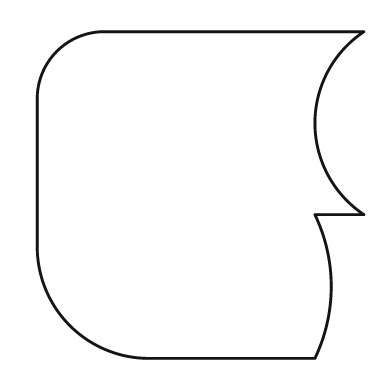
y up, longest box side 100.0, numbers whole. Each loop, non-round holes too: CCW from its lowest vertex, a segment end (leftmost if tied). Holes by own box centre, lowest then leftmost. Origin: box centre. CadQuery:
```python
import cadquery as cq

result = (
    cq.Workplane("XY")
    .moveTo(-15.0, -50.0)
    .lineTo(35.0, -50.0)
    .threePointArc((40.0, -28.0), (35.0, -6.0))
    .lineTo(50.0, -6.0)
    .threePointArc((35.0, 22.0), (50.0, 50.0))
    .lineTo(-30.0, 50.0)
    .threePointArc((-44.0, 44.0), (-50.0, 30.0))
    .lineTo(-50.0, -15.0)
    .threePointArc((-40.0, -40.0), (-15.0, -50.0))
    .close()
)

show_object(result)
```